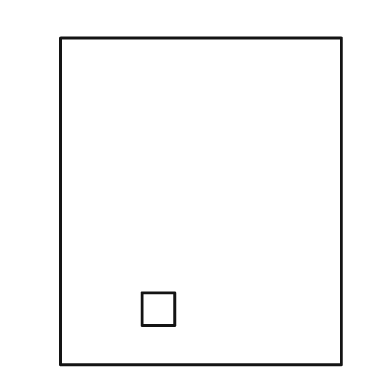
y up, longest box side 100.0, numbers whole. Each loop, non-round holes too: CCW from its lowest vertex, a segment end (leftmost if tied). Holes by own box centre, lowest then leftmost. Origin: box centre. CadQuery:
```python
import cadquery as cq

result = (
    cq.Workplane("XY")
    .moveTo(-43.0, -50.0)
    .lineTo(43.0, -50.0)
    .lineTo(43.0, 50.0)
    .lineTo(-43.0, 50.0)
    .close()
    .moveTo(-18.0, -38.0)
    .lineTo(-8.0, -38.0)
    .lineTo(-8.0, -28.0)
    .lineTo(-18.0, -28.0)
    .close()
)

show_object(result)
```